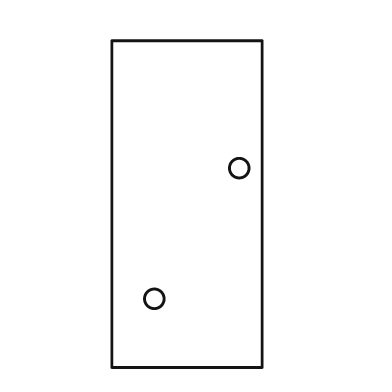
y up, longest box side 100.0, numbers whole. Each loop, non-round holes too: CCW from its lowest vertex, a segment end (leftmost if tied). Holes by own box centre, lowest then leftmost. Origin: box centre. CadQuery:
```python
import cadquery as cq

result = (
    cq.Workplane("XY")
    .moveTo(-23.0, -50.0)
    .lineTo(23.0, -50.0)
    .lineTo(23.0, 50.0)
    .lineTo(-23.0, 50.0)
    .close()
    .moveTo(-10.0, -29.0)
    .circle(3.0)
    .moveTo(16.0, 11.0)
    .circle(3.0)
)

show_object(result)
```